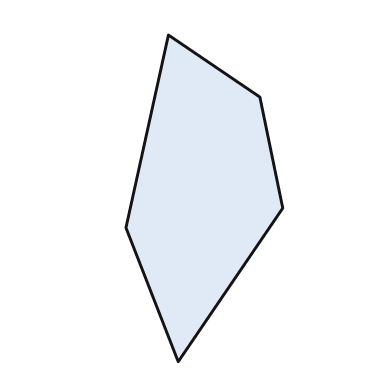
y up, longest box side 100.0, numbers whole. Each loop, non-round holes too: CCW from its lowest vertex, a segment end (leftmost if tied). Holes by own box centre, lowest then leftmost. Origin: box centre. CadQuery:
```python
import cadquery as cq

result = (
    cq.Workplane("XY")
    .moveTo(-8.0, -50.0)
    .lineTo(24.0, -3.0)
    .lineTo(17.0, 31.0)
    .lineTo(-11.0, 50.0)
    .lineTo(-24.0, -9.0)
    .close()
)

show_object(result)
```